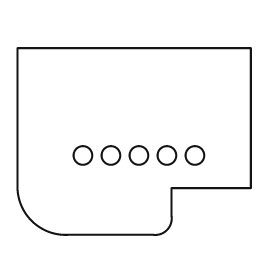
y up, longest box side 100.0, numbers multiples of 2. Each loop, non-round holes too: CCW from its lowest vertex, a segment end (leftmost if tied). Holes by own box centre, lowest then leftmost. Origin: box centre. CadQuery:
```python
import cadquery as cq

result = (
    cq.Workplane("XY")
    .moveTo(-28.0, -40.0)
    .lineTo(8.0, -40.0)
    .threePointArc((14.0, -38.0), (16.0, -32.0))
    .lineTo(16.0, -20.0)
    .lineTo(50.0, -20.0)
    .lineTo(50.0, 40.0)
    .lineTo(-50.0, 40.0)
    .lineTo(-50.0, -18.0)
    .threePointArc((-44.0, -34.0), (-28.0, -40.0))
    .close()
    .moveTo(-22.0, -6.0)
    .circle(4.0)
    .moveTo(-10.0, -6.0)
    .circle(4.0)
    .moveTo(2.0, -6.0)
    .circle(4.0)
    .moveTo(14.0, -6.0)
    .circle(4.0)
    .moveTo(26.0, -6.0)
    .circle(4.0)
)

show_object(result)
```